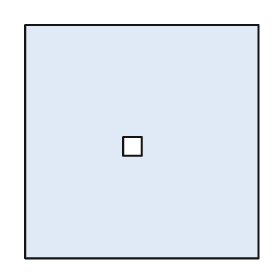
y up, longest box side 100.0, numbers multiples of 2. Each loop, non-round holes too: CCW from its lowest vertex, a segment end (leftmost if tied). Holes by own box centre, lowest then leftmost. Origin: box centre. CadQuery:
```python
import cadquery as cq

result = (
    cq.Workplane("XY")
    .moveTo(-50.0, -50.0)
    .lineTo(50.0, -50.0)
    .lineTo(50.0, 50.0)
    .lineTo(-50.0, 50.0)
    .close()
    .moveTo(-8.0, -6.0)
    .lineTo(0.0, -6.0)
    .lineTo(0.0, 2.0)
    .lineTo(-8.0, 2.0)
    .close()
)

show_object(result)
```